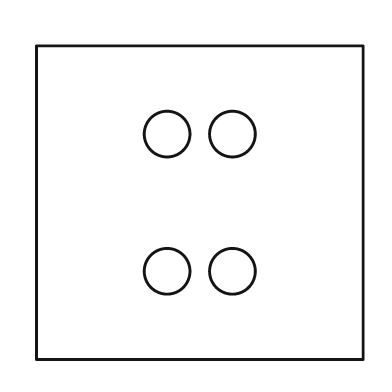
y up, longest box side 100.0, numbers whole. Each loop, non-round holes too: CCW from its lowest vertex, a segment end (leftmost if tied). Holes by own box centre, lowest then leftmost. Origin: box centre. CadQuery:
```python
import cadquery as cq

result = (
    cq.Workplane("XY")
    .moveTo(-50.0, -48.0)
    .lineTo(50.0, -48.0)
    .lineTo(50.0, 48.0)
    .lineTo(-50.0, 48.0)
    .close()
    .moveTo(-10.0, -21.0)
    .circle(7.0)
    .moveTo(10.0, -21.0)
    .circle(7.0)
    .moveTo(-10.0, 21.0)
    .circle(7.0)
    .moveTo(10.0, 21.0)
    .circle(7.0)
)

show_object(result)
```